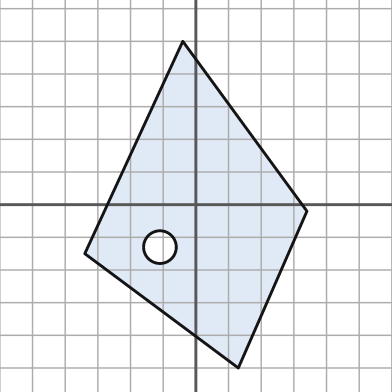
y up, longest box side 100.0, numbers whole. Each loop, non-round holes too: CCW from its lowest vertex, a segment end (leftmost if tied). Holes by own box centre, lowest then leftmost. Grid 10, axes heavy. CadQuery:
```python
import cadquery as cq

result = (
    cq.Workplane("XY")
    .moveTo(13.0, -50.0)
    .lineTo(34.0, -2.0)
    .lineTo(-4.0, 50.0)
    .lineTo(-34.0, -15.0)
    .close()
    .moveTo(-11.0, -13.0)
    .circle(5.0)
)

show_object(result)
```